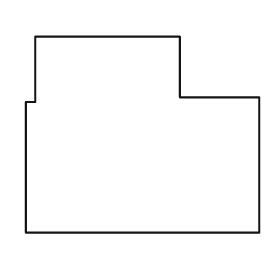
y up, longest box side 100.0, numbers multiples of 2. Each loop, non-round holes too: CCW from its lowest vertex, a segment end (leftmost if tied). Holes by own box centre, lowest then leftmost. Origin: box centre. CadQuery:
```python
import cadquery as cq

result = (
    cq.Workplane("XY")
    .moveTo(-50.0, -42.0)
    .lineTo(50.0, -42.0)
    .lineTo(50.0, 16.0)
    .lineTo(16.0, 16.0)
    .lineTo(16.0, 42.0)
    .lineTo(-46.0, 42.0)
    .lineTo(-46.0, 14.0)
    .lineTo(-50.0, 14.0)
    .close()
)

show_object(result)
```